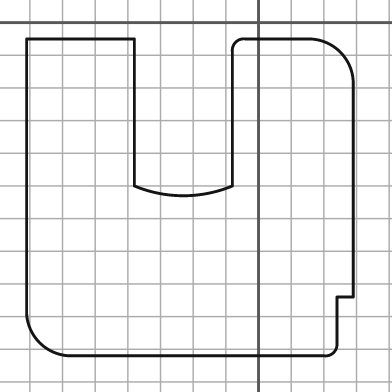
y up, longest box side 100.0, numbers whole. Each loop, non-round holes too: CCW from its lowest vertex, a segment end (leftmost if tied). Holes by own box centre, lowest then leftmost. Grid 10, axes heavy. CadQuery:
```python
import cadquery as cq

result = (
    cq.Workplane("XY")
    .moveTo(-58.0, -102.0)
    .lineTo(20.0, -102.0)
    .threePointArc((23.0, -101.0), (24.0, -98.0))
    .lineTo(24.0, -84.0)
    .lineTo(29.0, -84.0)
    .lineTo(29.0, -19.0)
    .threePointArc((25.0, -9.0), (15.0, -5.0))
    .lineTo(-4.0, -5.0)
    .threePointArc((-7.0, -6.0), (-8.0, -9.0))
    .lineTo(-8.0, -50.0)
    .threePointArc((-23.0, -53.0), (-38.0, -50.0))
    .lineTo(-38.0, -5.0)
    .lineTo(-71.0, -5.0)
    .lineTo(-71.0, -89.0)
    .threePointArc((-67.0, -98.0), (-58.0, -102.0))
    .close()
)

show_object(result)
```